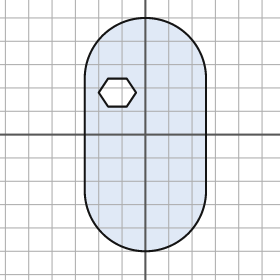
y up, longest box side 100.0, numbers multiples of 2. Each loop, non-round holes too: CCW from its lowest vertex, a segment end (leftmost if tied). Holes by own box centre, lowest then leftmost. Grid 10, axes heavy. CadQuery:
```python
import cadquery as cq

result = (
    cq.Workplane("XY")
    .moveTo(-26.0, -24.0)
    .threePointArc((0.0, -50.0), (26.0, -24.0))
    .lineTo(26.0, 24.0)
    .threePointArc((0.0, 50.0), (-26.0, 24.0))
    .close()
    .moveTo(-16.0, 12.0)
    .lineTo(-8.0, 12.0)
    .lineTo(-4.0, 18.0)
    .lineTo(-8.0, 24.0)
    .lineTo(-16.0, 24.0)
    .lineTo(-20.0, 18.0)
    .close()
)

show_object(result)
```